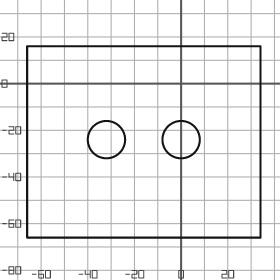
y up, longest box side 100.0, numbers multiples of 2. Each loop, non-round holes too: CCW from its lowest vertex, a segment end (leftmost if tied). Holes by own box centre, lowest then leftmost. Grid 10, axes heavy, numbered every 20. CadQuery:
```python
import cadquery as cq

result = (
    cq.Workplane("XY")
    .moveTo(-66.0, -66.0)
    .lineTo(34.0, -66.0)
    .lineTo(34.0, 16.0)
    .lineTo(-66.0, 16.0)
    .close()
    .moveTo(-32.0, -24.0)
    .circle(8.0)
    .moveTo(0.0, -24.0)
    .circle(8.0)
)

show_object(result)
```